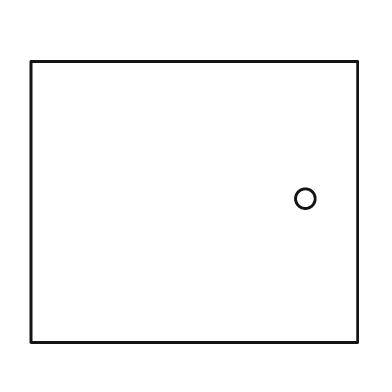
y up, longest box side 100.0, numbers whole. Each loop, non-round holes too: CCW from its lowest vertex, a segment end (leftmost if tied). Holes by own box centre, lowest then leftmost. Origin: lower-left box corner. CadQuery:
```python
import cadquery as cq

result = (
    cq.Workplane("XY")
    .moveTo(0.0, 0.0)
    .lineTo(100.0, 0.0)
    .lineTo(100.0, 86.0)
    .lineTo(0.0, 86.0)
    .close()
    .moveTo(84.0, 44.0)
    .circle(3.0)
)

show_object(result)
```